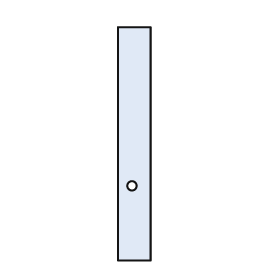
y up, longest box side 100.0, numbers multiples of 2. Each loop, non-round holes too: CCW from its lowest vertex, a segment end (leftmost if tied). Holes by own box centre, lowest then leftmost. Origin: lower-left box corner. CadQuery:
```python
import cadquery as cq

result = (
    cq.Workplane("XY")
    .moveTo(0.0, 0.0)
    .lineTo(14.0, 0.0)
    .lineTo(14.0, 100.0)
    .lineTo(0.0, 100.0)
    .close()
    .moveTo(6.0, 32.0)
    .circle(2.0)
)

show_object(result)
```